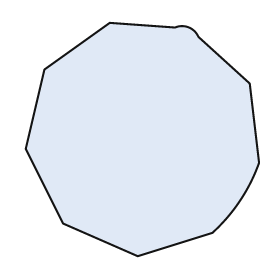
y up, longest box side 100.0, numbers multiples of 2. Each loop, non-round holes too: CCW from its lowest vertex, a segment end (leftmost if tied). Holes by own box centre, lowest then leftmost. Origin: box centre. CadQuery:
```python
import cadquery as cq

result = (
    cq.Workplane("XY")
    .moveTo(-2.0, -50.0)
    .lineTo(30.0, -40.0)
    .threePointArc((42.0, -26.0), (50.0, -10.0))
    .lineTo(46.0, 24.0)
    .lineTo(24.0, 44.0)
    .threePointArc((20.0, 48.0), (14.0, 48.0))
    .lineTo(-14.0, 50.0)
    .lineTo(-42.0, 30.0)
    .lineTo(-50.0, -4.0)
    .lineTo(-34.0, -36.0)
    .close()
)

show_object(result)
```